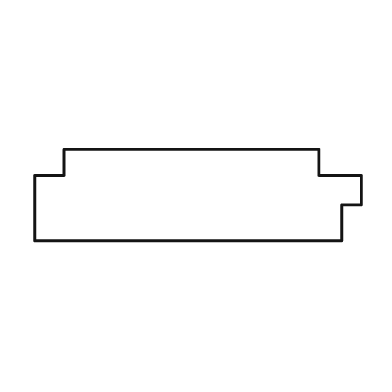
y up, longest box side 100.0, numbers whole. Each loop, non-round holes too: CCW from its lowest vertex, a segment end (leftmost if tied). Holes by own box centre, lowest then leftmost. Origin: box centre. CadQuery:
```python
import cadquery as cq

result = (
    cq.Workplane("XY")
    .moveTo(-50.0, -14.0)
    .lineTo(44.0, -14.0)
    .lineTo(44.0, -3.0)
    .lineTo(50.0, -3.0)
    .lineTo(50.0, 6.0)
    .lineTo(37.0, 6.0)
    .lineTo(37.0, 14.0)
    .lineTo(-41.0, 14.0)
    .lineTo(-41.0, 6.0)
    .lineTo(-50.0, 6.0)
    .close()
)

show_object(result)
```